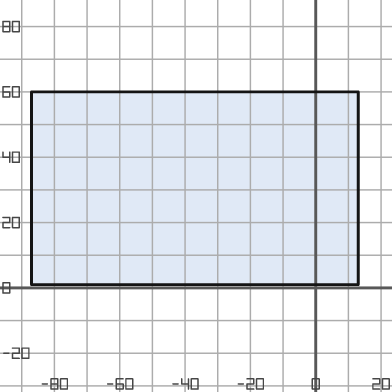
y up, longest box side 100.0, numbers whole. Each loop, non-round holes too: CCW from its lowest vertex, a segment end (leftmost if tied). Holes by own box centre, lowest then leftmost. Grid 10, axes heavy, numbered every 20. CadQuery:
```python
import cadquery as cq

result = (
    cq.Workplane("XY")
    .moveTo(-87.0, 1.0)
    .lineTo(13.0, 1.0)
    .lineTo(13.0, 60.0)
    .lineTo(-87.0, 60.0)
    .close()
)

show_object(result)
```